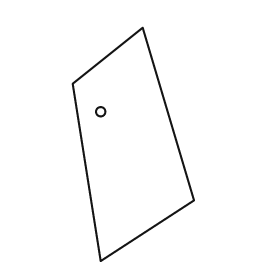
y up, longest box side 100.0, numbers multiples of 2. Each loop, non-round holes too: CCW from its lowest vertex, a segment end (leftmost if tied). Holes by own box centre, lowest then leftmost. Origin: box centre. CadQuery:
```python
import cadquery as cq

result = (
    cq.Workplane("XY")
    .moveTo(-14.0, -50.0)
    .lineTo(26.0, -24.0)
    .lineTo(4.0, 50.0)
    .lineTo(-26.0, 26.0)
    .close()
    .moveTo(-14.0, 14.0)
    .circle(2.0)
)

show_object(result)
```